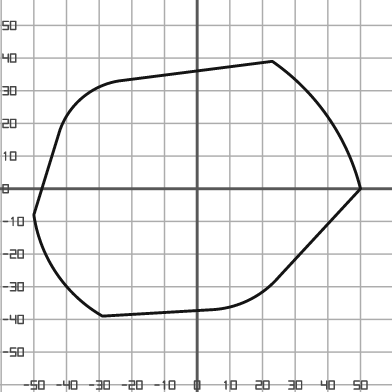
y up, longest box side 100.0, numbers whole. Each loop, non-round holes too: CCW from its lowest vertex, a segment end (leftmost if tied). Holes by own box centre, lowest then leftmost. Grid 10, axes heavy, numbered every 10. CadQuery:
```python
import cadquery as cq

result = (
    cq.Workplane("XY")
    .moveTo(-29.0, -39.0)
    .lineTo(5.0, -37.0)
    .threePointArc((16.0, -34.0), (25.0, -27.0))
    .lineTo(50.0, 0.0)
    .threePointArc((40.0, 22.0), (23.0, 39.0))
    .lineTo(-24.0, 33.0)
    .threePointArc((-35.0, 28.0), (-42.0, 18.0))
    .lineTo(-50.0, -8.0)
    .threePointArc((-43.0, -26.0), (-29.0, -39.0))
    .close()
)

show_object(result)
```